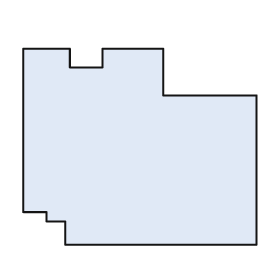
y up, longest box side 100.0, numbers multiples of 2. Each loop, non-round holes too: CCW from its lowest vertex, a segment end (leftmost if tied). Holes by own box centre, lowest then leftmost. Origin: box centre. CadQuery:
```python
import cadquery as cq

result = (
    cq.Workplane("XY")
    .moveTo(-32.0, -42.0)
    .lineTo(50.0, -42.0)
    .lineTo(50.0, 22.0)
    .lineTo(10.0, 22.0)
    .lineTo(10.0, 42.0)
    .lineTo(-16.0, 42.0)
    .lineTo(-16.0, 34.0)
    .lineTo(-30.0, 34.0)
    .lineTo(-30.0, 42.0)
    .lineTo(-50.0, 42.0)
    .lineTo(-50.0, -28.0)
    .lineTo(-40.0, -28.0)
    .lineTo(-40.0, -32.0)
    .lineTo(-32.0, -32.0)
    .close()
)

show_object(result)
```